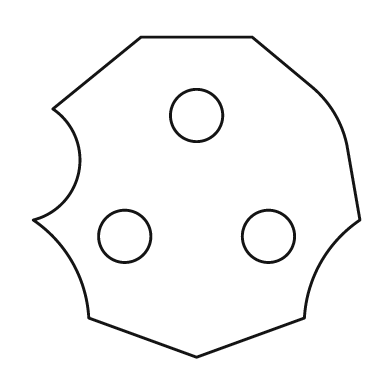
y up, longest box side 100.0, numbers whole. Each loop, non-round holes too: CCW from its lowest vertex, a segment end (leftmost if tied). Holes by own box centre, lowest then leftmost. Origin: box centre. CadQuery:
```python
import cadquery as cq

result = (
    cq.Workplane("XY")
    .moveTo(0.0, -49.0)
    .lineTo(33.0, -37.0)
    .threePointArc((38.0, -20.0), (50.0, -7.0))
    .lineTo(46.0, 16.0)
    .threePointArc((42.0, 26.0), (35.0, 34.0))
    .lineTo(17.0, 49.0)
    .lineTo(-17.0, 49.0)
    .lineTo(-44.0, 27.0)
    .threePointArc((-36.0, 8.0), (-50.0, -7.0))
    .threePointArc((-38.0, -20.0), (-33.0, -37.0))
    .close()
    .moveTo(-22.0, -12.0)
    .circle(8.0)
    .moveTo(22.0, -12.0)
    .circle(8.0)
    .moveTo(0.0, 25.0)
    .circle(8.0)
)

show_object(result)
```